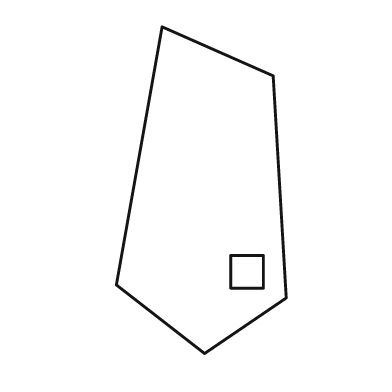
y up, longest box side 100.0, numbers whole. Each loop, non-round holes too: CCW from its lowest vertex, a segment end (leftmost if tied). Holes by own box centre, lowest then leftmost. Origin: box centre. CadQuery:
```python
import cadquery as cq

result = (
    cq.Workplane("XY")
    .moveTo(1.0, -50.0)
    .lineTo(26.0, -33.0)
    .lineTo(22.0, 35.0)
    .lineTo(-12.0, 50.0)
    .lineTo(-26.0, -29.0)
    .close()
    .moveTo(9.0, -30.0)
    .lineTo(19.0, -30.0)
    .lineTo(19.0, -20.0)
    .lineTo(9.0, -20.0)
    .close()
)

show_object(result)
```